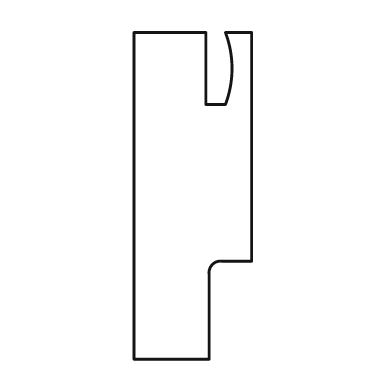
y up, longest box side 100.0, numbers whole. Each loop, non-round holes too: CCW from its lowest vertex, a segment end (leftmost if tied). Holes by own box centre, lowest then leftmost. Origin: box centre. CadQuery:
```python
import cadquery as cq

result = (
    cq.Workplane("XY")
    .moveTo(-18.0, -50.0)
    .lineTo(5.0, -50.0)
    .lineTo(5.0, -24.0)
    .threePointArc((6.0, -21.0), (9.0, -20.0))
    .lineTo(18.0, -20.0)
    .lineTo(18.0, 50.0)
    .lineTo(10.0, 50.0)
    .threePointArc((12.0, 39.0), (10.0, 28.0))
    .lineTo(4.0, 28.0)
    .lineTo(4.0, 50.0)
    .lineTo(-18.0, 50.0)
    .close()
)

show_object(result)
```